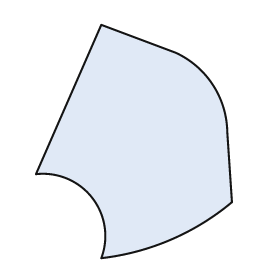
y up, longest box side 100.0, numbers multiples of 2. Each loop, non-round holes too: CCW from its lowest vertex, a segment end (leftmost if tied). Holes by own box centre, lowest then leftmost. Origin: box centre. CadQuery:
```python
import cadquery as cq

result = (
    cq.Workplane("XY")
    .moveTo(-14.0, -50.0)
    .threePointArc((16.0, -42.0), (42.0, -26.0))
    .lineTo(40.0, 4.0)
    .threePointArc((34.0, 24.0), (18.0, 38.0))
    .lineTo(-14.0, 50.0)
    .lineTo(-42.0, -14.0)
    .threePointArc((-18.0, -24.0), (-14.0, -50.0))
    .close()
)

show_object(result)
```